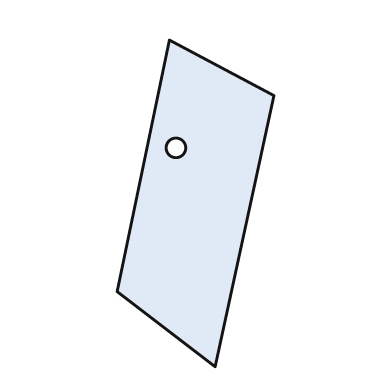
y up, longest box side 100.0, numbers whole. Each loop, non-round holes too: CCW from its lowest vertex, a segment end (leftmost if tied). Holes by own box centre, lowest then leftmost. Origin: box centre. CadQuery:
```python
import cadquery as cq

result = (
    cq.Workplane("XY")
    .moveTo(6.0, -50.0)
    .lineTo(24.0, 33.0)
    .lineTo(-8.0, 50.0)
    .lineTo(-24.0, -27.0)
    .close()
    .moveTo(-6.0, 17.0)
    .circle(3.0)
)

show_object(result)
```